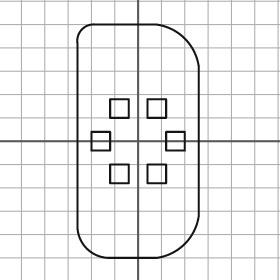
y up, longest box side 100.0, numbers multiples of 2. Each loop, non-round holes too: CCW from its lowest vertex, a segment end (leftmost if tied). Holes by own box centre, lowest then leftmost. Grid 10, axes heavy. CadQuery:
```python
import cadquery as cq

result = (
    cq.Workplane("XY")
    .moveTo(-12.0, -50.0)
    .lineTo(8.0, -50.0)
    .threePointArc((20.0, -44.0), (26.0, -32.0))
    .lineTo(26.0, 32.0)
    .threePointArc((20.0, 44.0), (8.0, 50.0))
    .lineTo(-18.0, 50.0)
    .threePointArc((-24.0, 48.0), (-26.0, 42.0))
    .lineTo(-26.0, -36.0)
    .threePointArc((-22.0, -46.0), (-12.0, -50.0))
    .close()
    .moveTo(-12.0, -18.0)
    .lineTo(-4.0, -18.0)
    .lineTo(-4.0, -10.0)
    .lineTo(-12.0, -10.0)
    .close()
    .moveTo(4.0, -18.0)
    .lineTo(12.0, -18.0)
    .lineTo(12.0, -10.0)
    .lineTo(4.0, -10.0)
    .close()
    .moveTo(-20.0, -4.0)
    .lineTo(-12.0, -4.0)
    .lineTo(-12.0, 4.0)
    .lineTo(-20.0, 4.0)
    .close()
    .moveTo(12.0, -4.0)
    .lineTo(20.0, -4.0)
    .lineTo(20.0, 4.0)
    .lineTo(12.0, 4.0)
    .close()
    .moveTo(-12.0, 10.0)
    .lineTo(-4.0, 10.0)
    .lineTo(-4.0, 18.0)
    .lineTo(-12.0, 18.0)
    .close()
    .moveTo(4.0, 10.0)
    .lineTo(12.0, 10.0)
    .lineTo(12.0, 18.0)
    .lineTo(4.0, 18.0)
    .close()
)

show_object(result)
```